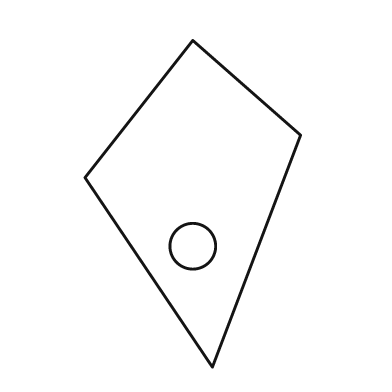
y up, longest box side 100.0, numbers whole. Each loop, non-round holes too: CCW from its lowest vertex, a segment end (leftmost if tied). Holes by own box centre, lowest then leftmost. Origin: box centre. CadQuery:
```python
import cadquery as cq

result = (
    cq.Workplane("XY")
    .moveTo(6.0, -50.0)
    .lineTo(33.0, 21.0)
    .lineTo(0.0, 50.0)
    .lineTo(-33.0, 8.0)
    .close()
    .moveTo(0.0, -13.0)
    .circle(7.0)
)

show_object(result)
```